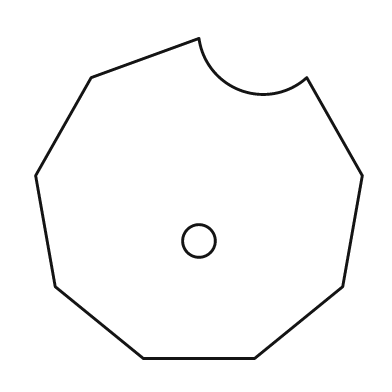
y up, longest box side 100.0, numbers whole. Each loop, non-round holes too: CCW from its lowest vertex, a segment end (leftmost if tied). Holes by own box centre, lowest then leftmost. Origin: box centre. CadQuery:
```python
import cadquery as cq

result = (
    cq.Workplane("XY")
    .moveTo(-17.0, -49.0)
    .lineTo(17.0, -49.0)
    .lineTo(44.0, -27.0)
    .lineTo(50.0, 7.0)
    .lineTo(33.0, 37.0)
    .threePointArc((13.0, 33.0), (0.0, 49.0))
    .lineTo(-33.0, 37.0)
    .lineTo(-50.0, 7.0)
    .lineTo(-44.0, -27.0)
    .close()
    .moveTo(0.0, -13.0)
    .circle(5.0)
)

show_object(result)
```